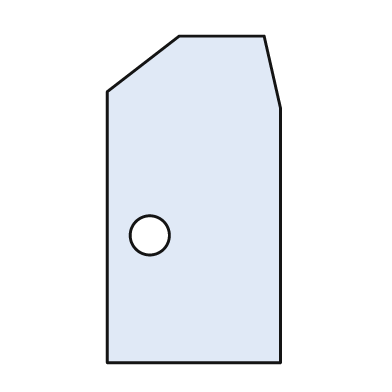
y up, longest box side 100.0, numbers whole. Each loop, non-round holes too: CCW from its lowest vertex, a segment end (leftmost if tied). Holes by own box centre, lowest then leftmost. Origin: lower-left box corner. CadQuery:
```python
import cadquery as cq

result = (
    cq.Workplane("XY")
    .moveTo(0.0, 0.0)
    .lineTo(53.0, 0.0)
    .lineTo(53.0, 78.0)
    .lineTo(48.0, 100.0)
    .lineTo(22.0, 100.0)
    .lineTo(0.0, 83.0)
    .close()
    .moveTo(13.0, 39.0)
    .circle(6.0)
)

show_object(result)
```